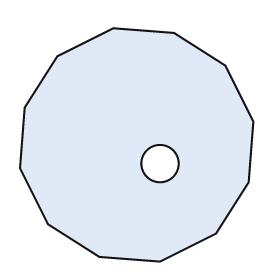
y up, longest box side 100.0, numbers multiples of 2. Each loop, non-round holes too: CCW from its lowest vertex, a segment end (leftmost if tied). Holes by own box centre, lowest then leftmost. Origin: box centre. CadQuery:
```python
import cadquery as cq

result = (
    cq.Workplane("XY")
    .moveTo(10.0, -50.0)
    .lineTo(34.0, -38.0)
    .lineTo(48.0, -16.0)
    .lineTo(50.0, 10.0)
    .lineTo(38.0, 34.0)
    .lineTo(16.0, 48.0)
    .lineTo(-10.0, 50.0)
    .lineTo(-34.0, 38.0)
    .lineTo(-48.0, 16.0)
    .lineTo(-50.0, -10.0)
    .lineTo(-38.0, -34.0)
    .lineTo(-16.0, -48.0)
    .close()
    .moveTo(10.0, -8.0)
    .circle(8.0)
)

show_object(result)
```